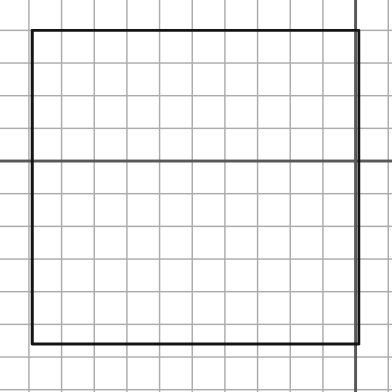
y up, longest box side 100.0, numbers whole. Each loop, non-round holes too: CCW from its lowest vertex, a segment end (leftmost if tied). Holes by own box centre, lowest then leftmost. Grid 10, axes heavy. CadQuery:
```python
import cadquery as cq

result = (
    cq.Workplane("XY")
    .moveTo(-99.0, -56.0)
    .lineTo(1.0, -56.0)
    .lineTo(1.0, 40.0)
    .lineTo(-99.0, 40.0)
    .close()
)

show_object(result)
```